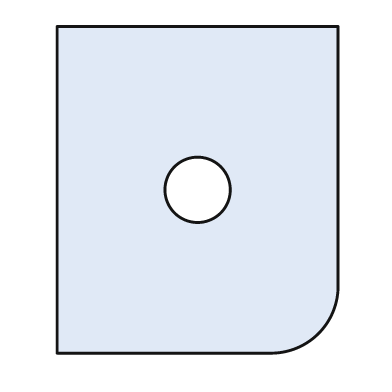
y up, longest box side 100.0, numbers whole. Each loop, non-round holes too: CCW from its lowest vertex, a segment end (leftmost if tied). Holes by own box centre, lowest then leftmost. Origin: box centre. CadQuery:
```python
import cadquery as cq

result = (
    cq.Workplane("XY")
    .moveTo(-43.0, -50.0)
    .lineTo(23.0, -50.0)
    .threePointArc((37.0, -44.0), (43.0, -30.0))
    .lineTo(43.0, 50.0)
    .lineTo(-43.0, 50.0)
    .close()
    .moveTo(0.0, 0.0)
    .circle(10.0)
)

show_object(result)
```